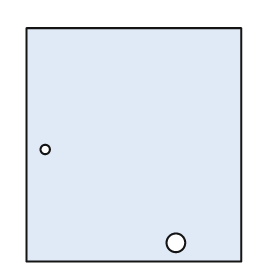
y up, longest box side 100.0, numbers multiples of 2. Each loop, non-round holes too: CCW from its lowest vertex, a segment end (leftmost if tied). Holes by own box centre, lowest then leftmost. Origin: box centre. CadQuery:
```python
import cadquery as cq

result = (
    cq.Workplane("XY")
    .moveTo(-46.0, -50.0)
    .lineTo(46.0, -50.0)
    .lineTo(46.0, 50.0)
    .lineTo(-46.0, 50.0)
    .close()
    .moveTo(18.0, -42.0)
    .circle(4.0)
    .moveTo(-38.0, -2.0)
    .circle(2.0)
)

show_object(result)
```